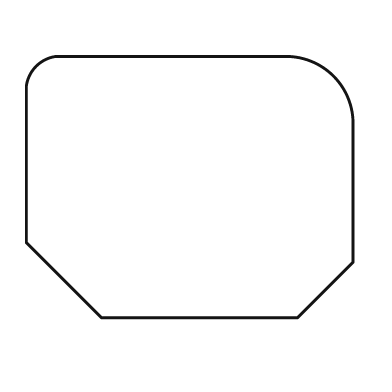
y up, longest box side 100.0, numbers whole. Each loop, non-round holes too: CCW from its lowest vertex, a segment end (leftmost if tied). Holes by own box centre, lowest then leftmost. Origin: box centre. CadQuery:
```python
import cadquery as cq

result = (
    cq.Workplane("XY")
    .moveTo(-27.0, -40.0)
    .lineTo(33.0, -40.0)
    .lineTo(50.0, -23.0)
    .lineTo(50.0, 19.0)
    .threePointArc((44.0, 34.0), (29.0, 40.0))
    .lineTo(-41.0, 40.0)
    .threePointArc((-47.0, 37.0), (-50.0, 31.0))
    .lineTo(-50.0, -17.0)
    .close()
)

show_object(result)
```